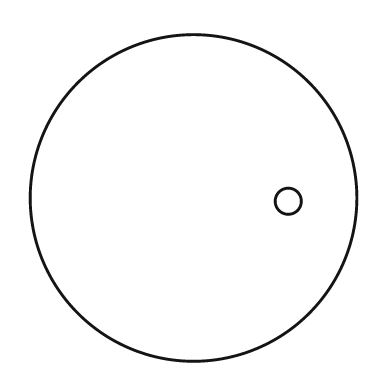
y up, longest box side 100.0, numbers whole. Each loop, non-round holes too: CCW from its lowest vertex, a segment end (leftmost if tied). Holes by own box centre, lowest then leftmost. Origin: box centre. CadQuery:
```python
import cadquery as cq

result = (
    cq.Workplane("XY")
    .moveTo(0.0, 0.0)
    .circle(50.0)
    .moveTo(29.0, -1.0)
    .circle(4.0)
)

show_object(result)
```